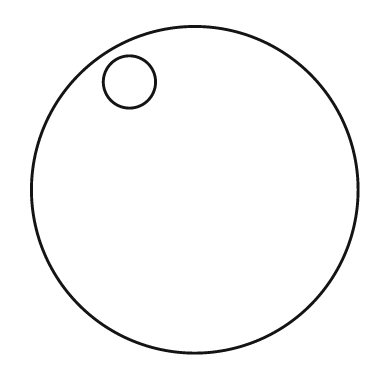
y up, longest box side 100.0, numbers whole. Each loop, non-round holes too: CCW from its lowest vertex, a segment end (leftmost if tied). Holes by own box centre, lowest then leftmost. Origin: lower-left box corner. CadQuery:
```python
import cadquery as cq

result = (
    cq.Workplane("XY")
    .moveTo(50.0, 50.0)
    .circle(50.0)
    .moveTo(30.0, 83.0)
    .circle(8.0)
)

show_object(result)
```